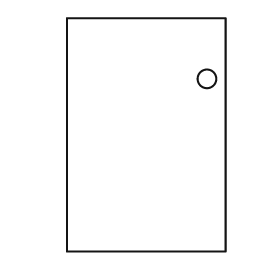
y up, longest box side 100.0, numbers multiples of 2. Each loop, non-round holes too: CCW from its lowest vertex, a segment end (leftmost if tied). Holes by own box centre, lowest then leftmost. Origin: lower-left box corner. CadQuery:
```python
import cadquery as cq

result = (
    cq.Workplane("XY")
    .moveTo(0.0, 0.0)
    .lineTo(68.0, 0.0)
    .lineTo(68.0, 100.0)
    .lineTo(0.0, 100.0)
    .close()
    .moveTo(60.0, 74.0)
    .circle(4.0)
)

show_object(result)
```